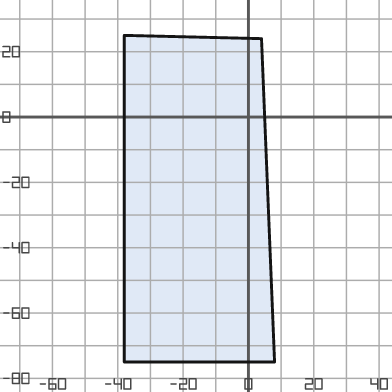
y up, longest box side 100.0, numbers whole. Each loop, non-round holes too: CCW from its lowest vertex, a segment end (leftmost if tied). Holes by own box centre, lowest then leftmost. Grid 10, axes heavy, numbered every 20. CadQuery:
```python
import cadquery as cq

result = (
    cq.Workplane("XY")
    .moveTo(-38.0, -75.0)
    .lineTo(8.0, -75.0)
    .lineTo(4.0, 24.0)
    .lineTo(-38.0, 25.0)
    .close()
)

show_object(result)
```